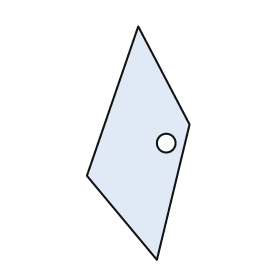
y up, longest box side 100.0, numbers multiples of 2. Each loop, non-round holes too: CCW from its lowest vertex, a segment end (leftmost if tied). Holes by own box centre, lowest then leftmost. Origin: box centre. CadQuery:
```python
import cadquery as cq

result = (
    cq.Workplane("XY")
    .moveTo(8.0, -50.0)
    .lineTo(22.0, 8.0)
    .lineTo(0.0, 50.0)
    .lineTo(-22.0, -14.0)
    .close()
    .moveTo(12.0, 0.0)
    .circle(4.0)
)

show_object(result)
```